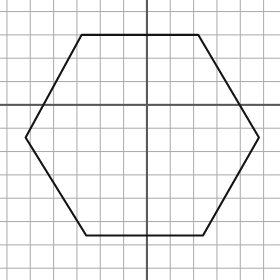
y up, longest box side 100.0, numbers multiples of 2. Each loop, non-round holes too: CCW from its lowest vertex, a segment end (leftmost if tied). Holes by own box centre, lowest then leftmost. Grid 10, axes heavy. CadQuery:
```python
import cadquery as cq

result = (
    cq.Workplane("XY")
    .moveTo(-26.0, -56.0)
    .lineTo(24.0, -56.0)
    .lineTo(48.0, -14.0)
    .lineTo(22.0, 30.0)
    .lineTo(-28.0, 30.0)
    .lineTo(-52.0, -14.0)
    .close()
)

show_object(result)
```